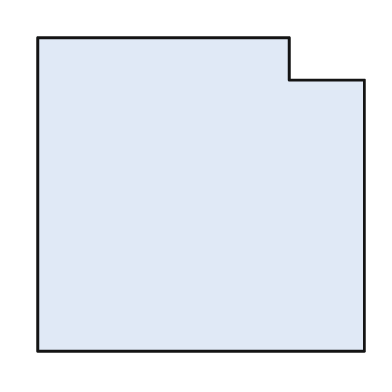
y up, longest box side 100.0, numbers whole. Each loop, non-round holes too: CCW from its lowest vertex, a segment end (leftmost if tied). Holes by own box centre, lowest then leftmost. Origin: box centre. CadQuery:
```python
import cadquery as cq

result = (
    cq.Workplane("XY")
    .moveTo(-50.0, -48.0)
    .lineTo(50.0, -48.0)
    .lineTo(50.0, 35.0)
    .lineTo(27.0, 35.0)
    .lineTo(27.0, 48.0)
    .lineTo(-50.0, 48.0)
    .close()
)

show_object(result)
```